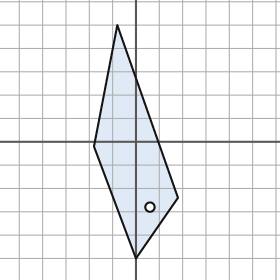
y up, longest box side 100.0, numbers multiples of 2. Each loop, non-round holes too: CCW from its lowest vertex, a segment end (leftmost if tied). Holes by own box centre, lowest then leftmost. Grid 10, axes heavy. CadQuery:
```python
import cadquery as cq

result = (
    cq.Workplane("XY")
    .moveTo(0.0, -50.0)
    .lineTo(18.0, -24.0)
    .lineTo(-8.0, 50.0)
    .lineTo(-18.0, -2.0)
    .close()
    .moveTo(6.0, -28.0)
    .circle(2.0)
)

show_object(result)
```